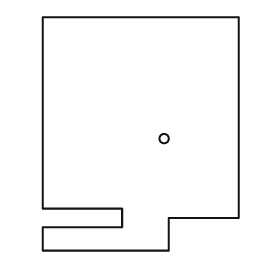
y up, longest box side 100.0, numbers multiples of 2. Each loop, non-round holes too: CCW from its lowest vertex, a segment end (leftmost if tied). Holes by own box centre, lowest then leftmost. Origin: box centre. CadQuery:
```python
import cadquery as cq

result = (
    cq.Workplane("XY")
    .moveTo(-42.0, -50.0)
    .lineTo(12.0, -50.0)
    .lineTo(12.0, -36.0)
    .lineTo(42.0, -36.0)
    .lineTo(42.0, 50.0)
    .lineTo(-42.0, 50.0)
    .lineTo(-42.0, -32.0)
    .lineTo(-8.0, -32.0)
    .lineTo(-8.0, -40.0)
    .lineTo(-42.0, -40.0)
    .close()
    .moveTo(10.0, -2.0)
    .circle(2.0)
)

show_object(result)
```